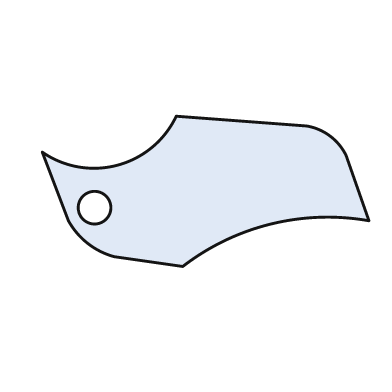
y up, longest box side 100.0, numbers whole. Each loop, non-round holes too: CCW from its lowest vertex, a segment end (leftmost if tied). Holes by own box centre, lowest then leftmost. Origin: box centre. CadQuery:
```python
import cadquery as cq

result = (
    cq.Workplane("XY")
    .moveTo(-7.0, -23.0)
    .threePointArc((20.0, -10.0), (50.0, -9.0))
    .lineTo(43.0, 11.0)
    .threePointArc((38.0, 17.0), (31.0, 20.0))
    .lineTo(-9.0, 23.0)
    .threePointArc((-27.0, 8.0), (-50.0, 12.0))
    .lineTo(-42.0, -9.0)
    .threePointArc((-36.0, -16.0), (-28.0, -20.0))
    .close()
    .moveTo(-34.0, -5.0)
    .circle(5.0)
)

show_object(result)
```